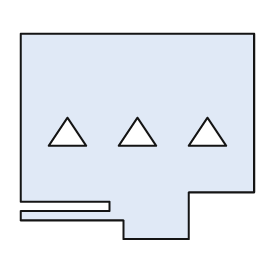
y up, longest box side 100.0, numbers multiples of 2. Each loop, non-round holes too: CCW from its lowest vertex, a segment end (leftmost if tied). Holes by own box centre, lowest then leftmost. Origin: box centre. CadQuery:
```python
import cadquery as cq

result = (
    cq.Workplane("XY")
    .moveTo(-6.0, -44.0)
    .lineTo(22.0, -44.0)
    .lineTo(22.0, -24.0)
    .lineTo(50.0, -24.0)
    .lineTo(50.0, 44.0)
    .lineTo(-50.0, 44.0)
    .lineTo(-50.0, -28.0)
    .lineTo(-12.0, -28.0)
    .lineTo(-12.0, -32.0)
    .lineTo(-50.0, -32.0)
    .lineTo(-50.0, -36.0)
    .lineTo(-6.0, -36.0)
    .close()
    .moveTo(-38.0, -4.0)
    .lineTo(-22.0, -4.0)
    .lineTo(-30.0, 8.0)
    .close()
    .moveTo(-8.0, -4.0)
    .lineTo(8.0, -4.0)
    .lineTo(0.0, 8.0)
    .close()
    .moveTo(22.0, -4.0)
    .lineTo(38.0, -4.0)
    .lineTo(30.0, 8.0)
    .close()
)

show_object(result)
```